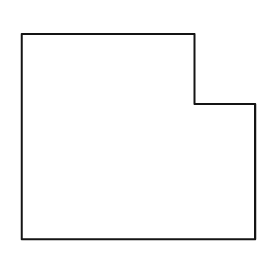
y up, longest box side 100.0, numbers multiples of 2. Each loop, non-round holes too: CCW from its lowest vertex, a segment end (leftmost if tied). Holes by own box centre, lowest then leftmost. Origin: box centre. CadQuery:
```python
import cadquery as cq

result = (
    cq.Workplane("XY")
    .moveTo(-50.0, -44.0)
    .lineTo(50.0, -44.0)
    .lineTo(50.0, 14.0)
    .lineTo(24.0, 14.0)
    .lineTo(24.0, 44.0)
    .lineTo(-50.0, 44.0)
    .close()
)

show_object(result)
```